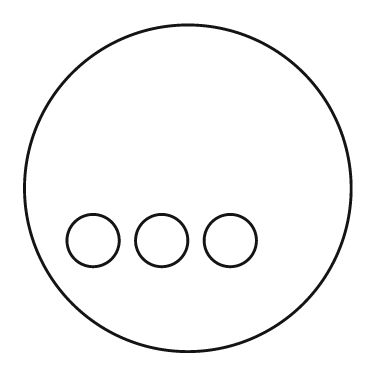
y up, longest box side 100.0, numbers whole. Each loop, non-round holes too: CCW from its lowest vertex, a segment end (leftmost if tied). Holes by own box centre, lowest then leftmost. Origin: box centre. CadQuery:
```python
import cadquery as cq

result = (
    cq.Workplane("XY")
    .moveTo(0.0, 0.0)
    .circle(50.0)
    .moveTo(-29.0, -16.0)
    .circle(8.0)
    .moveTo(-8.0, -16.0)
    .circle(8.0)
    .moveTo(13.0, -16.0)
    .circle(8.0)
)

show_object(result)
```